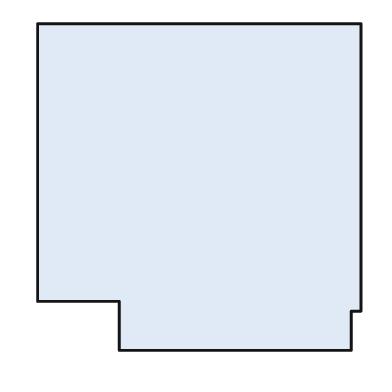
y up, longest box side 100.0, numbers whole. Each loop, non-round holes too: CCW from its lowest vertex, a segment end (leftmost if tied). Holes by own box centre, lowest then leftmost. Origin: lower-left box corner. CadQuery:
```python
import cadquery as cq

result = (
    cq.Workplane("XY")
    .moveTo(25.0, 0.0)
    .lineTo(96.0, 0.0)
    .lineTo(96.0, 12.0)
    .lineTo(99.0, 12.0)
    .lineTo(99.0, 100.0)
    .lineTo(0.0, 100.0)
    .lineTo(0.0, 15.0)
    .lineTo(25.0, 15.0)
    .close()
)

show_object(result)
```